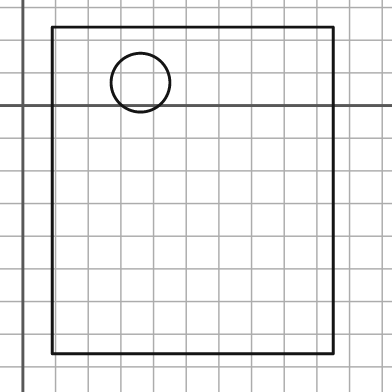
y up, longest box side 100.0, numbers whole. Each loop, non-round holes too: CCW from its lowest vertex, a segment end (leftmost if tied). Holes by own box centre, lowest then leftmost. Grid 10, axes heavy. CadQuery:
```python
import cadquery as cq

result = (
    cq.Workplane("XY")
    .moveTo(9.0, -76.0)
    .lineTo(95.0, -76.0)
    .lineTo(95.0, 24.0)
    .lineTo(9.0, 24.0)
    .close()
    .moveTo(36.0, 7.0)
    .circle(9.0)
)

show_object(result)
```